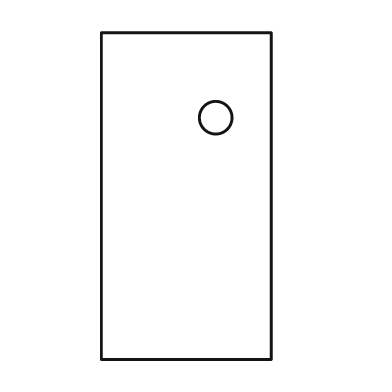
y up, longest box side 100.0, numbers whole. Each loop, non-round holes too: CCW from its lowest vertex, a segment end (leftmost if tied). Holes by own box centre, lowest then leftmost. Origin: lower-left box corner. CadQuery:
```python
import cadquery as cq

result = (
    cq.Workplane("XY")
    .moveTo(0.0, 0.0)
    .lineTo(52.0, 0.0)
    .lineTo(52.0, 100.0)
    .lineTo(0.0, 100.0)
    .close()
    .moveTo(35.0, 74.0)
    .circle(5.0)
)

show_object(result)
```